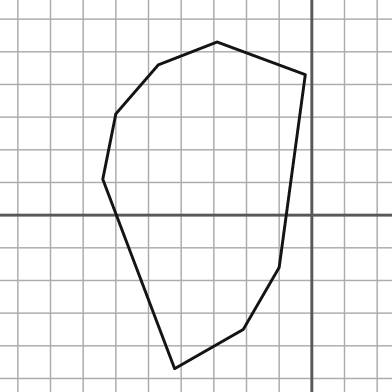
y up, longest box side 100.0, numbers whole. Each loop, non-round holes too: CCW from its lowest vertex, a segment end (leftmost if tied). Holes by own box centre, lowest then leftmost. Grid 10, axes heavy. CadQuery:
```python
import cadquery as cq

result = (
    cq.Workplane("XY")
    .moveTo(-42.0, -47.0)
    .lineTo(-21.0, -35.0)
    .lineTo(-10.0, -16.0)
    .lineTo(-2.0, 43.0)
    .lineTo(-29.0, 53.0)
    .lineTo(-47.0, 46.0)
    .lineTo(-60.0, 31.0)
    .lineTo(-64.0, 11.0)
    .close()
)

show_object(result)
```